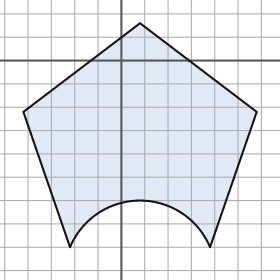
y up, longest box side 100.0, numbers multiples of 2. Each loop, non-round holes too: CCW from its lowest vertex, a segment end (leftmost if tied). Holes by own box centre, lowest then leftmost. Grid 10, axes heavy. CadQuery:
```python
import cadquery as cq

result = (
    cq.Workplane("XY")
    .moveTo(-22.0, -80.0)
    .threePointArc((8.0, -60.0), (38.0, -80.0))
    .lineTo(58.0, -22.0)
    .lineTo(8.0, 16.0)
    .lineTo(-42.0, -22.0)
    .close()
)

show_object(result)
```